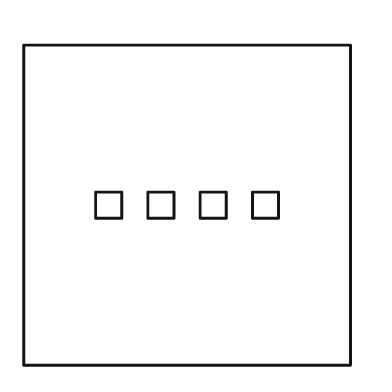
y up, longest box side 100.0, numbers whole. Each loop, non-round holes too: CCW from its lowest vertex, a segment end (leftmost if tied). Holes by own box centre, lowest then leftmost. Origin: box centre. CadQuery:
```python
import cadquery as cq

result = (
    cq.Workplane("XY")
    .moveTo(-50.0, -49.0)
    .lineTo(50.0, -49.0)
    .lineTo(50.0, 49.0)
    .lineTo(-50.0, 49.0)
    .close()
    .moveTo(-28.0, -4.0)
    .lineTo(-20.0, -4.0)
    .lineTo(-20.0, 4.0)
    .lineTo(-28.0, 4.0)
    .close()
    .moveTo(-12.0, -4.0)
    .lineTo(-4.0, -4.0)
    .lineTo(-4.0, 4.0)
    .lineTo(-12.0, 4.0)
    .close()
    .moveTo(4.0, -4.0)
    .lineTo(12.0, -4.0)
    .lineTo(12.0, 4.0)
    .lineTo(4.0, 4.0)
    .close()
    .moveTo(20.0, -4.0)
    .lineTo(28.0, -4.0)
    .lineTo(28.0, 4.0)
    .lineTo(20.0, 4.0)
    .close()
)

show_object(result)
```